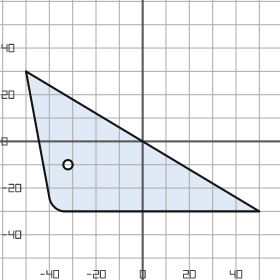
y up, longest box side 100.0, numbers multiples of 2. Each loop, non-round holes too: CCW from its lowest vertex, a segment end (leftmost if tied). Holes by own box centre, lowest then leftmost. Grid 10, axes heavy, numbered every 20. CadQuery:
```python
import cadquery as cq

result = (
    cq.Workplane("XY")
    .moveTo(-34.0, -30.0)
    .lineTo(50.0, -30.0)
    .lineTo(-50.0, 30.0)
    .lineTo(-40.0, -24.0)
    .threePointArc((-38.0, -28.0), (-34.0, -30.0))
    .close()
    .moveTo(-32.0, -10.0)
    .circle(2.0)
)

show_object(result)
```